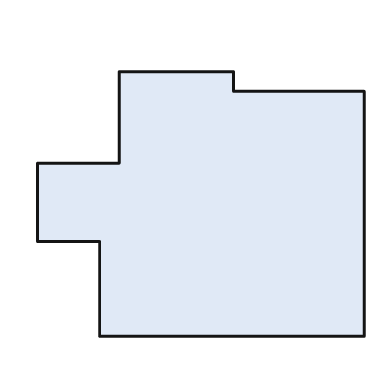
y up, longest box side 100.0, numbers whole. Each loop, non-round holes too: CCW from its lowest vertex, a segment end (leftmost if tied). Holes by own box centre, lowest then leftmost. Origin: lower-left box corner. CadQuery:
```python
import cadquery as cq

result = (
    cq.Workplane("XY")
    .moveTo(19.0, 0.0)
    .lineTo(100.0, 0.0)
    .lineTo(100.0, 75.0)
    .lineTo(60.0, 75.0)
    .lineTo(60.0, 81.0)
    .lineTo(25.0, 81.0)
    .lineTo(25.0, 53.0)
    .lineTo(0.0, 53.0)
    .lineTo(0.0, 29.0)
    .lineTo(19.0, 29.0)
    .close()
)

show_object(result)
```